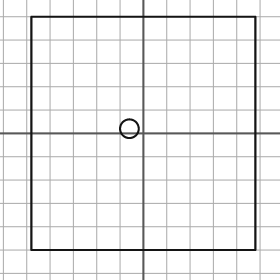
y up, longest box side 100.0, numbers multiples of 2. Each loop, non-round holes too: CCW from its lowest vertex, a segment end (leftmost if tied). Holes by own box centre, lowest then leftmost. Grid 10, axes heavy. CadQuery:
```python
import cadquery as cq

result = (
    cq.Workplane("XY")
    .moveTo(-48.0, -50.0)
    .lineTo(48.0, -50.0)
    .lineTo(48.0, 50.0)
    .lineTo(-48.0, 50.0)
    .close()
    .moveTo(-6.0, 2.0)
    .circle(4.0)
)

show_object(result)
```